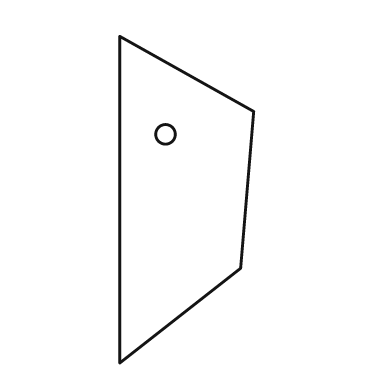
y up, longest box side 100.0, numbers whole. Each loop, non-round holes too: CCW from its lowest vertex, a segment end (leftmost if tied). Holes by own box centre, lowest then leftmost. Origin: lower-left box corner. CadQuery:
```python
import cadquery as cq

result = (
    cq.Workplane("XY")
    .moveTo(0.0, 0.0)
    .lineTo(37.0, 29.0)
    .lineTo(41.0, 77.0)
    .lineTo(0.0, 100.0)
    .close()
    .moveTo(14.0, 70.0)
    .circle(3.0)
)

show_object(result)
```